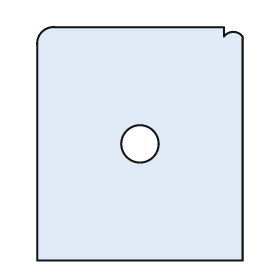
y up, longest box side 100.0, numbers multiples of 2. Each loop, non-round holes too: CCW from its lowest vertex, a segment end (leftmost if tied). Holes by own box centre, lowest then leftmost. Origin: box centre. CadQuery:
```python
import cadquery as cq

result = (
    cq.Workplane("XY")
    .moveTo(-44.0, -50.0)
    .lineTo(44.0, -50.0)
    .lineTo(44.0, 46.0)
    .threePointArc((40.0, 48.0), (36.0, 46.0))
    .lineTo(36.0, 50.0)
    .lineTo(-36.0, 50.0)
    .threePointArc((-42.0, 48.0), (-44.0, 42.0))
    .close()
    .moveTo(0.0, 0.0)
    .circle(8.0)
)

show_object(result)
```